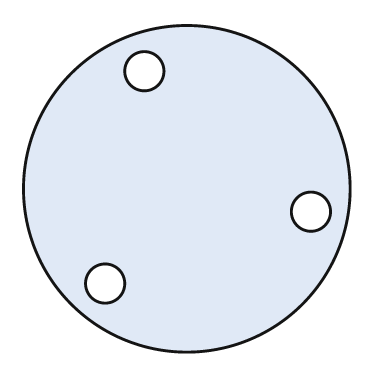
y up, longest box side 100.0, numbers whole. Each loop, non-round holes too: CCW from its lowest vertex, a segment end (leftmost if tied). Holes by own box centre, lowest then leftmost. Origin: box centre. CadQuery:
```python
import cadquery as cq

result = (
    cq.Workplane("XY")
    .moveTo(0.0, 0.0)
    .circle(50.0)
    .moveTo(-25.0, -29.0)
    .circle(6.0)
    .moveTo(38.0, -7.0)
    .circle(6.0)
    .moveTo(-13.0, 36.0)
    .circle(6.0)
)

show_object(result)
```